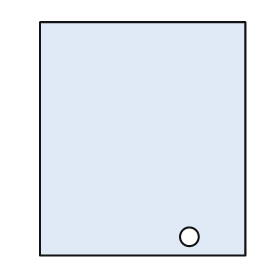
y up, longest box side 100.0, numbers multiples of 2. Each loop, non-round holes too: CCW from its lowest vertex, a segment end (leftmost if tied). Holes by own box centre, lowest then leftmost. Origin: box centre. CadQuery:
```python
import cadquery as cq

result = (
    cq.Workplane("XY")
    .moveTo(-44.0, -50.0)
    .lineTo(44.0, -50.0)
    .lineTo(44.0, 50.0)
    .lineTo(-44.0, 50.0)
    .close()
    .moveTo(20.0, -42.0)
    .circle(4.0)
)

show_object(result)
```